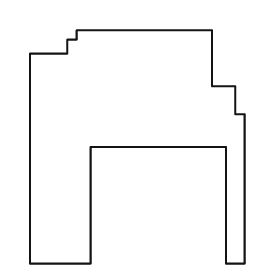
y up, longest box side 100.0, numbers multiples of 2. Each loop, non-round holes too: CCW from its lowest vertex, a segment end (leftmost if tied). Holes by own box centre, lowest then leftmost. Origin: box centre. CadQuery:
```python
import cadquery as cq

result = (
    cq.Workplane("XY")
    .moveTo(-46.0, -50.0)
    .lineTo(-20.0, -50.0)
    .lineTo(-20.0, 0.0)
    .lineTo(38.0, 0.0)
    .lineTo(38.0, -50.0)
    .lineTo(46.0, -50.0)
    .lineTo(46.0, 14.0)
    .lineTo(42.0, 14.0)
    .lineTo(42.0, 26.0)
    .lineTo(32.0, 26.0)
    .lineTo(32.0, 50.0)
    .lineTo(-26.0, 50.0)
    .lineTo(-26.0, 46.0)
    .lineTo(-30.0, 46.0)
    .lineTo(-30.0, 40.0)
    .lineTo(-46.0, 40.0)
    .close()
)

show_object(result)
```